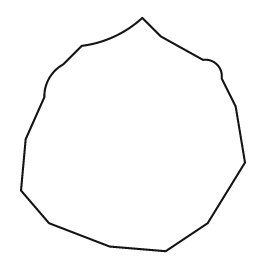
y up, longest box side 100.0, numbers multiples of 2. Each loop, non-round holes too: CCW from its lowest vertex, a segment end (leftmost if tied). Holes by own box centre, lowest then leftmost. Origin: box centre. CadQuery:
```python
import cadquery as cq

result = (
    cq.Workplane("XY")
    .moveTo(14.0, -50.0)
    .lineTo(32.0, -38.0)
    .lineTo(48.0, -12.0)
    .lineTo(44.0, 12.0)
    .lineTo(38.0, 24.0)
    .threePointArc((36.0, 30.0), (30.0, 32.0))
    .lineTo(12.0, 42.0)
    .lineTo(4.0, 50.0)
    .threePointArc((-8.0, 42.0), (-22.0, 38.0))
    .lineTo(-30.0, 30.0)
    .threePointArc((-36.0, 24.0), (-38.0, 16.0))
    .lineTo(-46.0, -2.0)
    .lineTo(-48.0, -24.0)
    .lineTo(-36.0, -38.0)
    .lineTo(-10.0, -48.0)
    .close()
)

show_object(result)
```